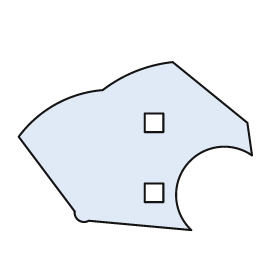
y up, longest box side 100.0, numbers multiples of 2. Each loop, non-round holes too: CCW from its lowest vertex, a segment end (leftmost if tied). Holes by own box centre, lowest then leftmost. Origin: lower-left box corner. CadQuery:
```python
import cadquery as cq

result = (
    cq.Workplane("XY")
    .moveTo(74.0, 0.0)
    .threePointArc((72.0, 28.0), (100.0, 32.0))
    .lineTo(98.0, 46.0)
    .lineTo(66.0, 72.0)
    .threePointArc((50.0, 68.0), (36.0, 60.0))
    .threePointArc((16.0, 54.0), (0.0, 40.0))
    .lineTo(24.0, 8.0)
    .threePointArc((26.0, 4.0), (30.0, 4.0))
    .close()
    .moveTo(54.0, 12.0)
    .lineTo(62.0, 12.0)
    .lineTo(62.0, 20.0)
    .lineTo(54.0, 20.0)
    .close()
    .moveTo(54.0, 42.0)
    .lineTo(62.0, 42.0)
    .lineTo(62.0, 50.0)
    .lineTo(54.0, 50.0)
    .close()
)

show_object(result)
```